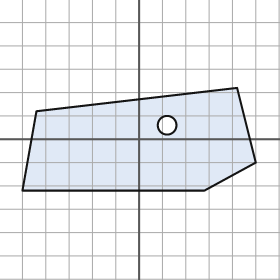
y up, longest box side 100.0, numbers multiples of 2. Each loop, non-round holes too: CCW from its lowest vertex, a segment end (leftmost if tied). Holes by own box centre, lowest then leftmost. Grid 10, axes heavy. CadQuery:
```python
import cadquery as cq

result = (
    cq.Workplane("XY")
    .moveTo(-50.0, -22.0)
    .lineTo(28.0, -22.0)
    .lineTo(50.0, -10.0)
    .lineTo(42.0, 22.0)
    .lineTo(-44.0, 12.0)
    .close()
    .moveTo(12.0, 6.0)
    .circle(4.0)
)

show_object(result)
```